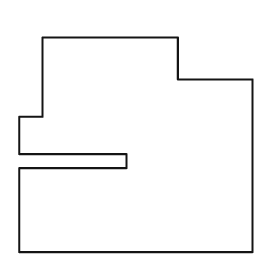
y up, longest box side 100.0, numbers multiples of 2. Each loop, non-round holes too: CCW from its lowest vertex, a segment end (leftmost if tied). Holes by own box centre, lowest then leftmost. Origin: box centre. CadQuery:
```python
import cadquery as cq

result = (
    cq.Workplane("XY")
    .moveTo(-50.0, -46.0)
    .lineTo(50.0, -46.0)
    .lineTo(50.0, 28.0)
    .lineTo(18.0, 28.0)
    .lineTo(18.0, 46.0)
    .lineTo(-40.0, 46.0)
    .lineTo(-40.0, 12.0)
    .lineTo(-50.0, 12.0)
    .lineTo(-50.0, -4.0)
    .lineTo(-4.0, -4.0)
    .lineTo(-4.0, -10.0)
    .lineTo(-50.0, -10.0)
    .close()
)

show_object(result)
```